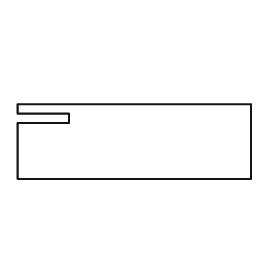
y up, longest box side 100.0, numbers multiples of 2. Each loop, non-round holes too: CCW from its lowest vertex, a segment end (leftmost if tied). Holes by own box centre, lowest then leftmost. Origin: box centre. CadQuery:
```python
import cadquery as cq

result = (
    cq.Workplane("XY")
    .moveTo(-50.0, -16.0)
    .lineTo(50.0, -16.0)
    .lineTo(50.0, 16.0)
    .lineTo(-50.0, 16.0)
    .lineTo(-50.0, 12.0)
    .lineTo(-28.0, 12.0)
    .lineTo(-28.0, 8.0)
    .lineTo(-50.0, 8.0)
    .close()
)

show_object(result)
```